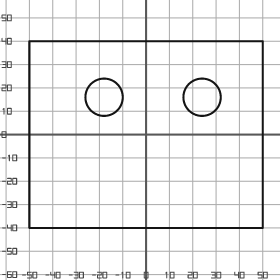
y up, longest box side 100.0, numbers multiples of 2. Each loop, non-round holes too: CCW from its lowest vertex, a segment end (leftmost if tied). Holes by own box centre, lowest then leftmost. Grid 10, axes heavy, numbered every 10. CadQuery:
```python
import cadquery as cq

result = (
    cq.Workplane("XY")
    .moveTo(-50.0, -40.0)
    .lineTo(50.0, -40.0)
    .lineTo(50.0, 40.0)
    .lineTo(-50.0, 40.0)
    .close()
    .moveTo(-18.0, 16.0)
    .circle(8.0)
    .moveTo(24.0, 16.0)
    .circle(8.0)
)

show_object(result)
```